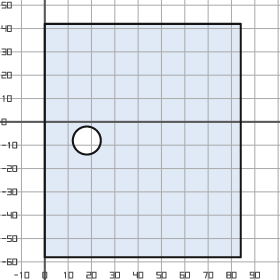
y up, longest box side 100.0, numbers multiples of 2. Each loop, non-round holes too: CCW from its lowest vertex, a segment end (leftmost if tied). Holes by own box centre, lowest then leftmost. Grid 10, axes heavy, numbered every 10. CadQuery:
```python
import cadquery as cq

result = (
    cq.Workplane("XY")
    .moveTo(0.0, -58.0)
    .lineTo(84.0, -58.0)
    .lineTo(84.0, 42.0)
    .lineTo(0.0, 42.0)
    .close()
    .moveTo(18.0, -8.0)
    .circle(6.0)
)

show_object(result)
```